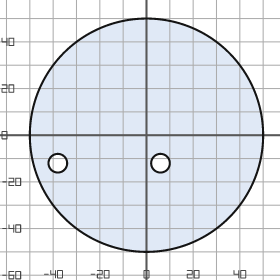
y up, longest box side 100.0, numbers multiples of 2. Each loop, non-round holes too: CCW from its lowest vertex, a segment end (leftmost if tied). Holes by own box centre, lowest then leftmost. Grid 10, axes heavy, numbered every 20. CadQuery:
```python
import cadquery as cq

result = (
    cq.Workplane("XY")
    .moveTo(0.0, 0.0)
    .circle(50.0)
    .moveTo(-38.0, -12.0)
    .circle(4.0)
    .moveTo(6.0, -12.0)
    .circle(4.0)
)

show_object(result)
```